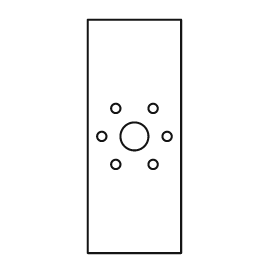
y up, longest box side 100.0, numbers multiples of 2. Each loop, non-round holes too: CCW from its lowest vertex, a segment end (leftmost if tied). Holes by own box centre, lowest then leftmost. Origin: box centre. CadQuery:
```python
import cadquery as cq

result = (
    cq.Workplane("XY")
    .moveTo(-20.0, -50.0)
    .lineTo(20.0, -50.0)
    .lineTo(20.0, 50.0)
    .lineTo(-20.0, 50.0)
    .close()
    .moveTo(-8.0, -12.0)
    .circle(2.0)
    .moveTo(8.0, -12.0)
    .circle(2.0)
    .moveTo(-14.0, 0.0)
    .circle(2.0)
    .moveTo(0.0, 0.0)
    .circle(6.0)
    .moveTo(14.0, 0.0)
    .circle(2.0)
    .moveTo(-8.0, 12.0)
    .circle(2.0)
    .moveTo(8.0, 12.0)
    .circle(2.0)
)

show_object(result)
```